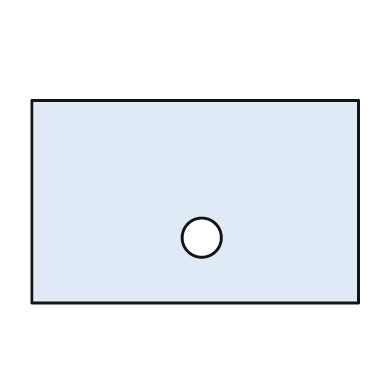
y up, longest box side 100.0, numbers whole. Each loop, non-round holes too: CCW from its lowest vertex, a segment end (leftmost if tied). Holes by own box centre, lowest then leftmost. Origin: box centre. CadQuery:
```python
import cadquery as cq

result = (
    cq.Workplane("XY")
    .moveTo(-50.0, -31.0)
    .lineTo(50.0, -31.0)
    .lineTo(50.0, 31.0)
    .lineTo(-50.0, 31.0)
    .close()
    .moveTo(2.0, -11.0)
    .circle(6.0)
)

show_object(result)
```